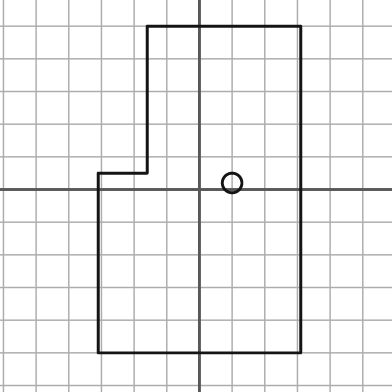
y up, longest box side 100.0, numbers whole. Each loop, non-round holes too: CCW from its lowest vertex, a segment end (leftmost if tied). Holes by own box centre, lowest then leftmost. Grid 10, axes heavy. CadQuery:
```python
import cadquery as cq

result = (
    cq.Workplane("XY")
    .moveTo(-31.0, -50.0)
    .lineTo(31.0, -50.0)
    .lineTo(31.0, 50.0)
    .lineTo(-16.0, 50.0)
    .lineTo(-16.0, 5.0)
    .lineTo(-31.0, 5.0)
    .close()
    .moveTo(10.0, 2.0)
    .circle(3.0)
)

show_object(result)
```